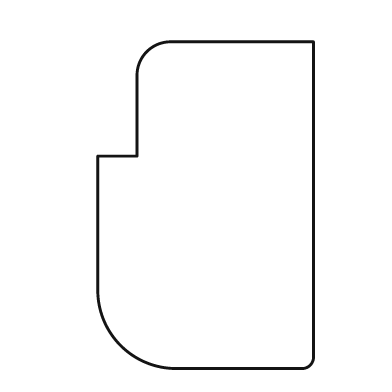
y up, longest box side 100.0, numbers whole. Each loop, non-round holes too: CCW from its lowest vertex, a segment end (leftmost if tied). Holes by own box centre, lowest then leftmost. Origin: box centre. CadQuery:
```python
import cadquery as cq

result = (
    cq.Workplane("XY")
    .moveTo(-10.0, -50.0)
    .lineTo(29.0, -50.0)
    .threePointArc((32.0, -49.0), (33.0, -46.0))
    .lineTo(33.0, 50.0)
    .lineTo(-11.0, 50.0)
    .threePointArc((-18.0, 47.0), (-21.0, 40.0))
    .lineTo(-21.0, 15.0)
    .lineTo(-33.0, 15.0)
    .lineTo(-33.0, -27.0)
    .threePointArc((-26.0, -43.0), (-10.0, -50.0))
    .close()
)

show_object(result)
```